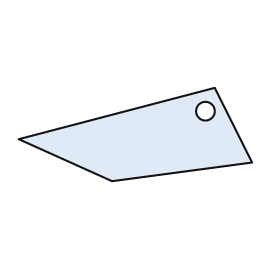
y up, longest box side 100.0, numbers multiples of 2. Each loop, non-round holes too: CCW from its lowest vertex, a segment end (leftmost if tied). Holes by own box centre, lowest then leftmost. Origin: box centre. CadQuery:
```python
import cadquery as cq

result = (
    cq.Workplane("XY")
    .moveTo(-10.0, -20.0)
    .lineTo(50.0, -12.0)
    .lineTo(34.0, 20.0)
    .lineTo(-50.0, -2.0)
    .close()
    .moveTo(30.0, 10.0)
    .circle(4.0)
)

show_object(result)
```